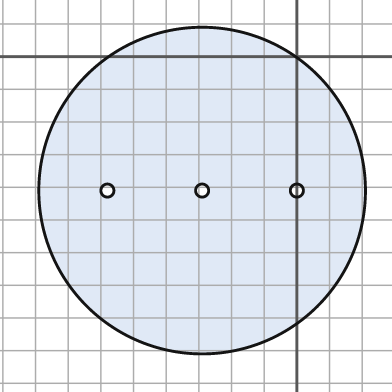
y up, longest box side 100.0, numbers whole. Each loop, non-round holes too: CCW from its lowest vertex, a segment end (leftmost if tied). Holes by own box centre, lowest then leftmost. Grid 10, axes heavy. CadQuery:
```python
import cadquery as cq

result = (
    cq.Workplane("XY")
    .moveTo(-29.0, -41.0)
    .circle(50.0)
    .moveTo(-58.0, -41.0)
    .circle(2.0)
    .moveTo(-29.0, -41.0)
    .circle(2.0)
    .moveTo(0.0, -41.0)
    .circle(2.0)
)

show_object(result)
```